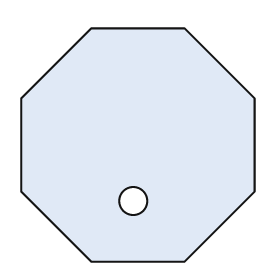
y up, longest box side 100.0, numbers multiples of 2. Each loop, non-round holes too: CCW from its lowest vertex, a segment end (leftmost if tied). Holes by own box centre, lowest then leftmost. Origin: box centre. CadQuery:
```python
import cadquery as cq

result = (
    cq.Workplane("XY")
    .moveTo(-20.0, -50.0)
    .lineTo(20.0, -50.0)
    .lineTo(50.0, -20.0)
    .lineTo(50.0, 20.0)
    .lineTo(20.0, 50.0)
    .lineTo(-20.0, 50.0)
    .lineTo(-50.0, 20.0)
    .lineTo(-50.0, -20.0)
    .close()
    .moveTo(-2.0, -24.0)
    .circle(6.0)
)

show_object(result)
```